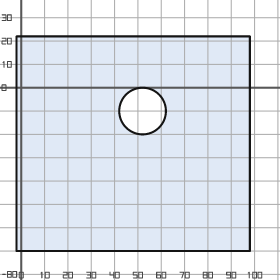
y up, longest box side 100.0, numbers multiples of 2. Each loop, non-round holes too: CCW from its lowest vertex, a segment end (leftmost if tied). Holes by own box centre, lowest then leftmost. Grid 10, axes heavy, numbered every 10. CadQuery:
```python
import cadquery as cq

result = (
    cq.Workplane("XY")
    .moveTo(-2.0, -70.0)
    .lineTo(98.0, -70.0)
    .lineTo(98.0, 22.0)
    .lineTo(-2.0, 22.0)
    .close()
    .moveTo(52.0, -10.0)
    .circle(10.0)
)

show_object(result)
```